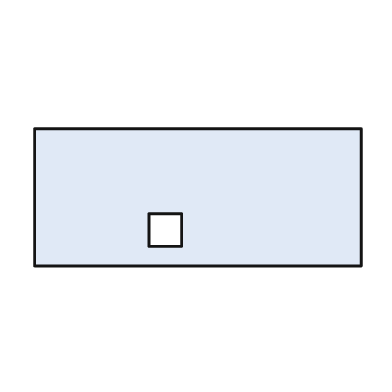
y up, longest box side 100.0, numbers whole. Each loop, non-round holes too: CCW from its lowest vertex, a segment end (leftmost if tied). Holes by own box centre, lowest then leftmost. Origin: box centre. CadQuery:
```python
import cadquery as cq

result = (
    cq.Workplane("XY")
    .moveTo(-50.0, -21.0)
    .lineTo(50.0, -21.0)
    .lineTo(50.0, 21.0)
    .lineTo(-50.0, 21.0)
    .close()
    .moveTo(-15.0, -15.0)
    .lineTo(-5.0, -15.0)
    .lineTo(-5.0, -5.0)
    .lineTo(-15.0, -5.0)
    .close()
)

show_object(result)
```